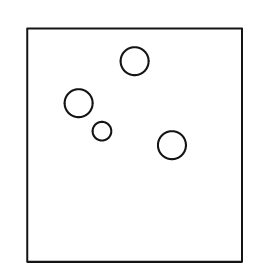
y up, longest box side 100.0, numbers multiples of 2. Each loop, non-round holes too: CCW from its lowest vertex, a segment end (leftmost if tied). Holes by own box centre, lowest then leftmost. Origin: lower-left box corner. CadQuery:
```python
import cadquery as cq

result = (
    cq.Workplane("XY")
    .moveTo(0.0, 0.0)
    .lineTo(92.0, 0.0)
    .lineTo(92.0, 100.0)
    .lineTo(0.0, 100.0)
    .close()
    .moveTo(62.0, 50.0)
    .circle(6.0)
    .moveTo(32.0, 56.0)
    .circle(4.0)
    .moveTo(22.0, 68.0)
    .circle(6.0)
    .moveTo(46.0, 86.0)
    .circle(6.0)
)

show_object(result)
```